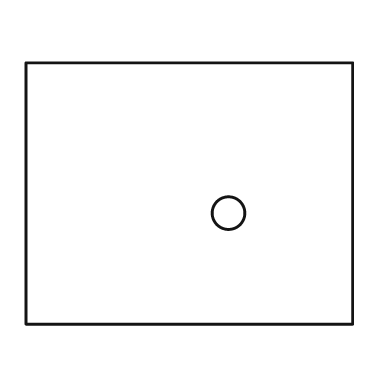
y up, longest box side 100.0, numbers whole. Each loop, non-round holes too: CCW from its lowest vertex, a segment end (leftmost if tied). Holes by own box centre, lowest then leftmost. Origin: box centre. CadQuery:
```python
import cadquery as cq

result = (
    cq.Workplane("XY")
    .moveTo(-50.0, -40.0)
    .lineTo(50.0, -40.0)
    .lineTo(50.0, 40.0)
    .lineTo(-50.0, 40.0)
    .close()
    .moveTo(12.0, -6.0)
    .circle(5.0)
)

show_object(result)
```